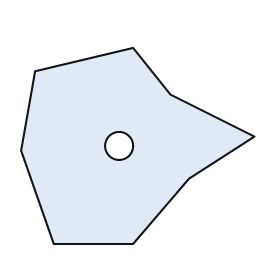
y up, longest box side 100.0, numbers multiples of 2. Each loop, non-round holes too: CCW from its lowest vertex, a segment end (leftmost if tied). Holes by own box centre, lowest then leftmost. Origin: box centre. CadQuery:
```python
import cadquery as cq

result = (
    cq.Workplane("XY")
    .moveTo(-36.0, -42.0)
    .lineTo(-2.0, -42.0)
    .lineTo(22.0, -14.0)
    .lineTo(50.0, 4.0)
    .lineTo(14.0, 22.0)
    .lineTo(-2.0, 42.0)
    .lineTo(-44.0, 32.0)
    .lineTo(-50.0, -2.0)
    .close()
    .moveTo(-8.0, 0.0)
    .circle(6.0)
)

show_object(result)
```